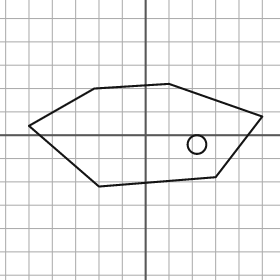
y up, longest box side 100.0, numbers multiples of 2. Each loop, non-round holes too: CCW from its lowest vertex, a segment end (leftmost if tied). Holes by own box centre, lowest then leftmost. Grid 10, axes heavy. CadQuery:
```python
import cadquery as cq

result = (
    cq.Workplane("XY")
    .moveTo(-20.0, -22.0)
    .lineTo(30.0, -18.0)
    .lineTo(50.0, 8.0)
    .lineTo(10.0, 22.0)
    .lineTo(-22.0, 20.0)
    .lineTo(-50.0, 4.0)
    .close()
    .moveTo(22.0, -4.0)
    .circle(4.0)
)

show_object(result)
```